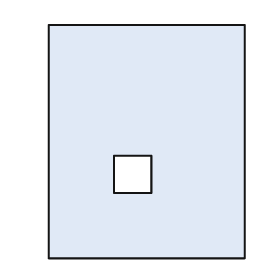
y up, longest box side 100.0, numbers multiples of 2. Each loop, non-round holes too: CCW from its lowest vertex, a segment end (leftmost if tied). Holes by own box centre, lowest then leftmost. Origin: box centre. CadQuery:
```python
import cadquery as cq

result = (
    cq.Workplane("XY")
    .moveTo(-42.0, -50.0)
    .lineTo(42.0, -50.0)
    .lineTo(42.0, 50.0)
    .lineTo(-42.0, 50.0)
    .close()
    .moveTo(-14.0, -22.0)
    .lineTo(2.0, -22.0)
    .lineTo(2.0, -6.0)
    .lineTo(-14.0, -6.0)
    .close()
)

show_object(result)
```